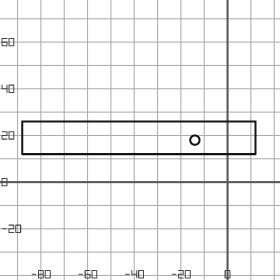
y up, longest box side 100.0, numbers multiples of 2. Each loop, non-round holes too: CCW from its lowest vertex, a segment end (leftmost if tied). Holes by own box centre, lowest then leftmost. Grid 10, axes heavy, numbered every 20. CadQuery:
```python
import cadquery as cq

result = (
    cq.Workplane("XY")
    .moveTo(-88.0, 12.0)
    .lineTo(12.0, 12.0)
    .lineTo(12.0, 26.0)
    .lineTo(-88.0, 26.0)
    .close()
    .moveTo(-14.0, 18.0)
    .circle(2.0)
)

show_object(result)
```